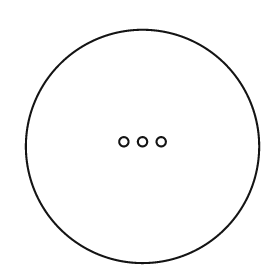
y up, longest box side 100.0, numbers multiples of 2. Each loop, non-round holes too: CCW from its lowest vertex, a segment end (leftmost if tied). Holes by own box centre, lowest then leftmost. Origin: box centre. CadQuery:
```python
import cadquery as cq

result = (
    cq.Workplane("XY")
    .moveTo(0.0, 0.0)
    .circle(50.0)
    .moveTo(-8.0, 2.0)
    .circle(2.0)
    .moveTo(0.0, 2.0)
    .circle(2.0)
    .moveTo(8.0, 2.0)
    .circle(2.0)
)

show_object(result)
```